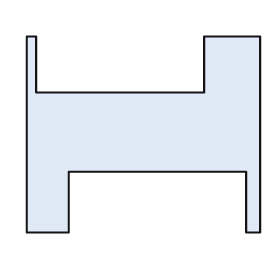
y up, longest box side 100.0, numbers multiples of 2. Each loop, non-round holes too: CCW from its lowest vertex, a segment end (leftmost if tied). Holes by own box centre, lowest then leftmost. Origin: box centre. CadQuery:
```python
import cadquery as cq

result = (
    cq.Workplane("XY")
    .moveTo(-50.0, -42.0)
    .lineTo(-32.0, -42.0)
    .lineTo(-32.0, -16.0)
    .lineTo(44.0, -16.0)
    .lineTo(44.0, -42.0)
    .lineTo(50.0, -42.0)
    .lineTo(50.0, 42.0)
    .lineTo(26.0, 42.0)
    .lineTo(26.0, 18.0)
    .lineTo(-46.0, 18.0)
    .lineTo(-46.0, 42.0)
    .lineTo(-50.0, 42.0)
    .close()
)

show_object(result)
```